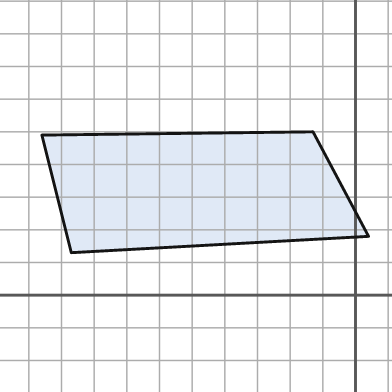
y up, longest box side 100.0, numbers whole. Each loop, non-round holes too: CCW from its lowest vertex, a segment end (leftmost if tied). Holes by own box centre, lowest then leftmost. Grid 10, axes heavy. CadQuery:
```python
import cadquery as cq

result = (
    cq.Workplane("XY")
    .moveTo(-87.0, 13.0)
    .lineTo(4.0, 18.0)
    .lineTo(-13.0, 50.0)
    .lineTo(-96.0, 49.0)
    .close()
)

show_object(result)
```